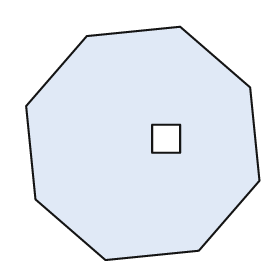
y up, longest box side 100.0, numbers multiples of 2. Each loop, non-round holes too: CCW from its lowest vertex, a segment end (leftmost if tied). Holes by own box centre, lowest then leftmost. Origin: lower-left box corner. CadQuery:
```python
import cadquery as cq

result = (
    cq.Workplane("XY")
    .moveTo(34.0, 0.0)
    .lineTo(74.0, 4.0)
    .lineTo(100.0, 34.0)
    .lineTo(96.0, 74.0)
    .lineTo(66.0, 100.0)
    .lineTo(26.0, 96.0)
    .lineTo(0.0, 66.0)
    .lineTo(4.0, 26.0)
    .close()
    .moveTo(54.0, 46.0)
    .lineTo(66.0, 46.0)
    .lineTo(66.0, 58.0)
    .lineTo(54.0, 58.0)
    .close()
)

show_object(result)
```